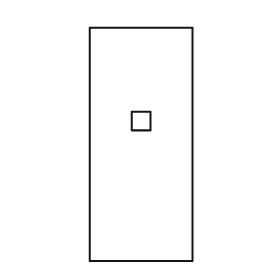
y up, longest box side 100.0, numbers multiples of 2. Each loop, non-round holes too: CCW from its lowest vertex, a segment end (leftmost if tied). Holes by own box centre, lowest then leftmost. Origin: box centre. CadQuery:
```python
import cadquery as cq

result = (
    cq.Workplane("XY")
    .moveTo(-22.0, -50.0)
    .lineTo(22.0, -50.0)
    .lineTo(22.0, 50.0)
    .lineTo(-22.0, 50.0)
    .close()
    .moveTo(-4.0, 6.0)
    .lineTo(4.0, 6.0)
    .lineTo(4.0, 14.0)
    .lineTo(-4.0, 14.0)
    .close()
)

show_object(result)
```